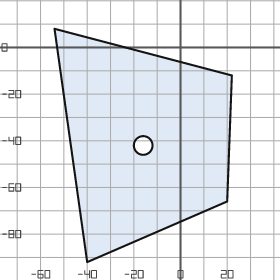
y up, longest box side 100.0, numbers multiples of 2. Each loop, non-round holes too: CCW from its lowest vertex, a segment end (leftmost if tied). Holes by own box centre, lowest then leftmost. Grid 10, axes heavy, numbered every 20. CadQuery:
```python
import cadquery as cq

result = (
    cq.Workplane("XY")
    .moveTo(-40.0, -92.0)
    .lineTo(20.0, -66.0)
    .lineTo(22.0, -12.0)
    .lineTo(-54.0, 8.0)
    .close()
    .moveTo(-16.0, -42.0)
    .circle(4.0)
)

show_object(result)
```